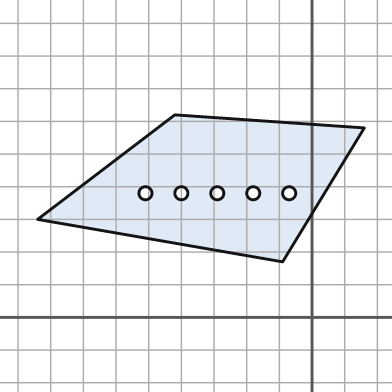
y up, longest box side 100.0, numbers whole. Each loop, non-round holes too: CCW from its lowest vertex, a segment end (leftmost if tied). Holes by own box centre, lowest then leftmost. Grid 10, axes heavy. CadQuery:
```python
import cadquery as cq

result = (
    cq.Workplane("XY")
    .moveTo(-9.0, 17.0)
    .lineTo(16.0, 58.0)
    .lineTo(-42.0, 62.0)
    .lineTo(-84.0, 30.0)
    .close()
    .moveTo(-51.0, 38.0)
    .circle(2.0)
    .moveTo(-40.0, 38.0)
    .circle(2.0)
    .moveTo(-29.0, 38.0)
    .circle(2.0)
    .moveTo(-18.0, 38.0)
    .circle(2.0)
    .moveTo(-7.0, 38.0)
    .circle(2.0)
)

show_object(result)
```